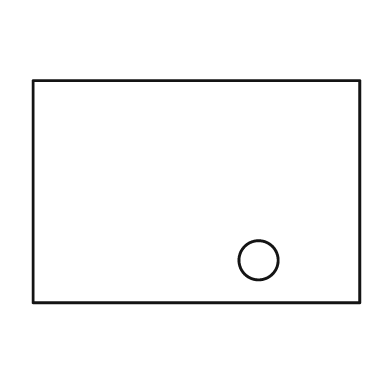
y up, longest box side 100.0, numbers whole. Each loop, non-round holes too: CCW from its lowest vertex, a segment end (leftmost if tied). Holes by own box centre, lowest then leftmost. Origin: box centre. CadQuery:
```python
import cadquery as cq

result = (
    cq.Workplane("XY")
    .moveTo(-50.0, -34.0)
    .lineTo(50.0, -34.0)
    .lineTo(50.0, 34.0)
    .lineTo(-50.0, 34.0)
    .close()
    .moveTo(19.0, -21.0)
    .circle(6.0)
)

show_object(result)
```